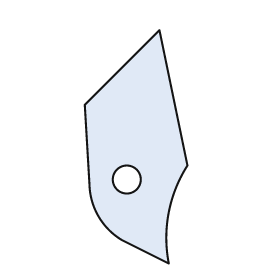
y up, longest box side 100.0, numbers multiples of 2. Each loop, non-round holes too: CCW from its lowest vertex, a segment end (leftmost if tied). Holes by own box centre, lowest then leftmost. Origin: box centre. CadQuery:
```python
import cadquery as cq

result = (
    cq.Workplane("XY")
    .moveTo(14.0, -50.0)
    .threePointArc((14.0, -28.0), (22.0, -8.0))
    .lineTo(10.0, 50.0)
    .lineTo(-22.0, 18.0)
    .lineTo(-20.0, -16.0)
    .threePointArc((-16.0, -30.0), (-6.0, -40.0))
    .close()
    .moveTo(-4.0, -14.0)
    .circle(6.0)
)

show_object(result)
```